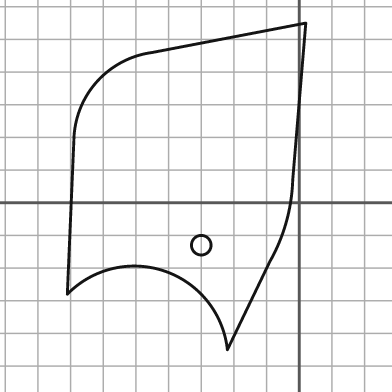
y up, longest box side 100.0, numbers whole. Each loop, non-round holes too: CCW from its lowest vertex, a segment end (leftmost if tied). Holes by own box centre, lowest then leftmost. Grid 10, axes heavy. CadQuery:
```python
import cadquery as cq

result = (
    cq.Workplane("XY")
    .moveTo(-22.0, -45.0)
    .lineTo(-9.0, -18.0)
    .threePointArc((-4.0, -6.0), (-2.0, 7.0))
    .lineTo(2.0, 55.0)
    .lineTo(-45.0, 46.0)
    .threePointArc((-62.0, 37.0), (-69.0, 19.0))
    .lineTo(-71.0, -28.0)
    .threePointArc((-41.0, -21.0), (-22.0, -45.0))
    .close()
    .moveTo(-30.0, -13.0)
    .circle(3.0)
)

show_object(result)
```